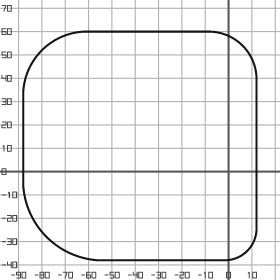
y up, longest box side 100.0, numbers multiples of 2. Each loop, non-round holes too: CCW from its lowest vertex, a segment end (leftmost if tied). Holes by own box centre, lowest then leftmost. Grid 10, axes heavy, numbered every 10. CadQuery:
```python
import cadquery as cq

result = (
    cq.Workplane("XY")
    .moveTo(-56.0, -38.0)
    .lineTo(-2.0, -38.0)
    .threePointArc((8.0, -34.0), (12.0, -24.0))
    .lineTo(12.0, 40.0)
    .threePointArc((6.0, 54.0), (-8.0, 60.0))
    .lineTo(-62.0, 60.0)
    .threePointArc((-80.0, 52.0), (-88.0, 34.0))
    .lineTo(-88.0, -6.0)
    .threePointArc((-78.0, -28.0), (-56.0, -38.0))
    .close()
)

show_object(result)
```